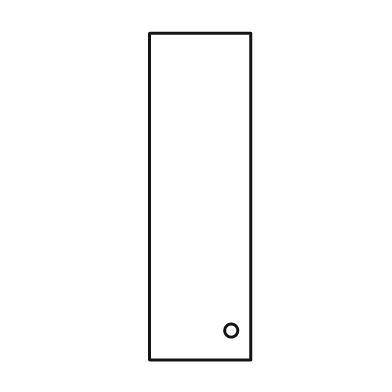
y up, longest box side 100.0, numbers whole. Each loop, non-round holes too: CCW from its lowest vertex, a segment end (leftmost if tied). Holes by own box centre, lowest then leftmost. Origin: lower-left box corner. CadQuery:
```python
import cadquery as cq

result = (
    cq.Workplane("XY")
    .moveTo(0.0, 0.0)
    .lineTo(31.0, 0.0)
    .lineTo(31.0, 100.0)
    .lineTo(0.0, 100.0)
    .close()
    .moveTo(25.0, 9.0)
    .circle(2.0)
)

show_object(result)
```